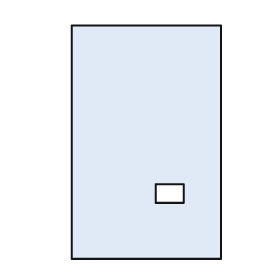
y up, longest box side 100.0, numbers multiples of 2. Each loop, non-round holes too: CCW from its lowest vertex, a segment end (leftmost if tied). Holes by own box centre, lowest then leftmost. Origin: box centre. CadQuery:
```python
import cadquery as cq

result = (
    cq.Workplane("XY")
    .moveTo(-32.0, -50.0)
    .lineTo(32.0, -50.0)
    .lineTo(32.0, 50.0)
    .lineTo(-32.0, 50.0)
    .close()
    .moveTo(4.0, -26.0)
    .lineTo(16.0, -26.0)
    .lineTo(16.0, -18.0)
    .lineTo(4.0, -18.0)
    .close()
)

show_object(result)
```